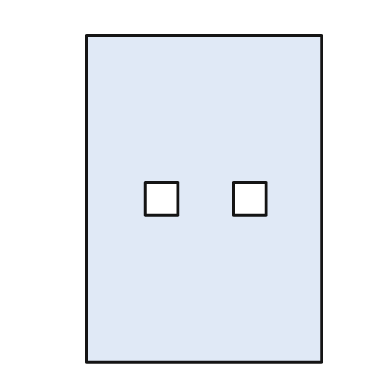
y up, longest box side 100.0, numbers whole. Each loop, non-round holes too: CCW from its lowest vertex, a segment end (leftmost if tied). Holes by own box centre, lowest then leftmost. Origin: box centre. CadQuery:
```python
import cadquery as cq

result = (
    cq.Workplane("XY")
    .moveTo(-36.0, -50.0)
    .lineTo(36.0, -50.0)
    .lineTo(36.0, 50.0)
    .lineTo(-36.0, 50.0)
    .close()
    .moveTo(-18.0, -5.0)
    .lineTo(-8.0, -5.0)
    .lineTo(-8.0, 5.0)
    .lineTo(-18.0, 5.0)
    .close()
    .moveTo(9.0, -5.0)
    .lineTo(19.0, -5.0)
    .lineTo(19.0, 5.0)
    .lineTo(9.0, 5.0)
    .close()
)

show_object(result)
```